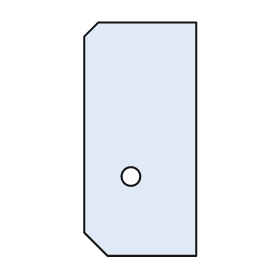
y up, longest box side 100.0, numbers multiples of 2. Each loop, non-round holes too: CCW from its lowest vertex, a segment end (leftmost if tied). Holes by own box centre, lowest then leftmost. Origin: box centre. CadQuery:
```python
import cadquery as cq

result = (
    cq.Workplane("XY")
    .moveTo(-14.0, -50.0)
    .lineTo(24.0, -50.0)
    .lineTo(24.0, 50.0)
    .lineTo(-18.0, 50.0)
    .lineTo(-24.0, 44.0)
    .lineTo(-24.0, -40.0)
    .close()
    .moveTo(-4.0, -16.0)
    .circle(4.0)
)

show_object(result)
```